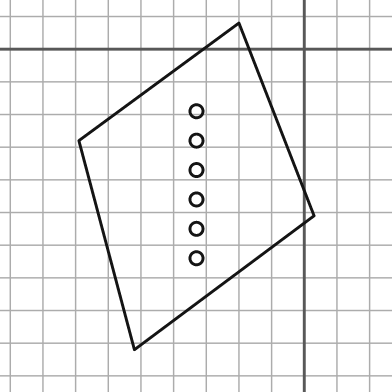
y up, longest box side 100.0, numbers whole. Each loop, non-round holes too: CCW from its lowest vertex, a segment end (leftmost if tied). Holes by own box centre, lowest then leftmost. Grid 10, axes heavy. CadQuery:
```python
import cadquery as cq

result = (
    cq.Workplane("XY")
    .moveTo(-52.0, -92.0)
    .lineTo(3.0, -51.0)
    .lineTo(-20.0, 8.0)
    .lineTo(-69.0, -28.0)
    .close()
    .moveTo(-33.0, -64.0)
    .circle(2.0)
    .moveTo(-33.0, -55.0)
    .circle(2.0)
    .moveTo(-33.0, -46.0)
    .circle(2.0)
    .moveTo(-33.0, -37.0)
    .circle(2.0)
    .moveTo(-33.0, -28.0)
    .circle(2.0)
    .moveTo(-33.0, -19.0)
    .circle(2.0)
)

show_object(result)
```